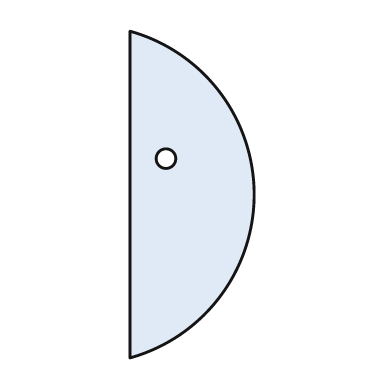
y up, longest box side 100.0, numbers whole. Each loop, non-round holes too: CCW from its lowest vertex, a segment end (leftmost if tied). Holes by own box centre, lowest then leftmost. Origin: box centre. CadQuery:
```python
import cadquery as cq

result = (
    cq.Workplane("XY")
    .moveTo(-19.0, -50.0)
    .threePointArc((19.0, 0.0), (-19.0, 50.0))
    .close()
    .moveTo(-8.0, 11.0)
    .circle(3.0)
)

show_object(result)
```